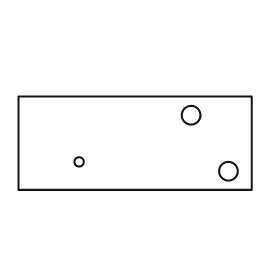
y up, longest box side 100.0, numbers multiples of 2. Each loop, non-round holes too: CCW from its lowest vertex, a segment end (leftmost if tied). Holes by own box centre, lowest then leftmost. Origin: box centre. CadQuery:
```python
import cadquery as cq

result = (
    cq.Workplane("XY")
    .moveTo(-50.0, -20.0)
    .lineTo(50.0, -20.0)
    .lineTo(50.0, 20.0)
    .lineTo(-50.0, 20.0)
    .close()
    .moveTo(40.0, -12.0)
    .circle(4.0)
    .moveTo(-24.0, -8.0)
    .circle(2.0)
    .moveTo(24.0, 12.0)
    .circle(4.0)
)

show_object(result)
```